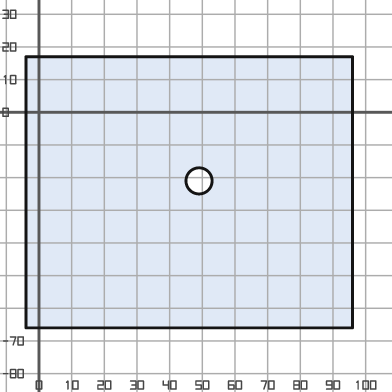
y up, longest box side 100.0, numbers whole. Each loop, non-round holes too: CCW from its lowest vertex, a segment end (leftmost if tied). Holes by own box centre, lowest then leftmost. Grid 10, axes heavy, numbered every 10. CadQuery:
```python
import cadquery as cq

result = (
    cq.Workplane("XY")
    .moveTo(-4.0, -66.0)
    .lineTo(96.0, -66.0)
    .lineTo(96.0, 17.0)
    .lineTo(-4.0, 17.0)
    .close()
    .moveTo(49.0, -21.0)
    .circle(4.0)
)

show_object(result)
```